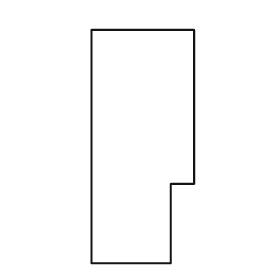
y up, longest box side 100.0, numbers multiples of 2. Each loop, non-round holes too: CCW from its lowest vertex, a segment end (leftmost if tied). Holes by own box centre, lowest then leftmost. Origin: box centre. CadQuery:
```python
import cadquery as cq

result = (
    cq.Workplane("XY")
    .moveTo(-22.0, -50.0)
    .lineTo(12.0, -50.0)
    .lineTo(12.0, -16.0)
    .lineTo(22.0, -16.0)
    .lineTo(22.0, 50.0)
    .lineTo(-22.0, 50.0)
    .close()
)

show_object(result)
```